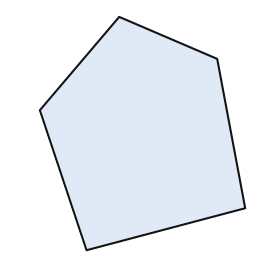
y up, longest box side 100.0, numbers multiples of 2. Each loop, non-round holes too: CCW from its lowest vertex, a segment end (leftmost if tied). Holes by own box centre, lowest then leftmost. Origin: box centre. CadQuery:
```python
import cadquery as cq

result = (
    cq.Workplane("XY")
    .moveTo(-24.0, -50.0)
    .lineTo(44.0, -32.0)
    .lineTo(32.0, 32.0)
    .lineTo(-10.0, 50.0)
    .lineTo(-44.0, 10.0)
    .close()
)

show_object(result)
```